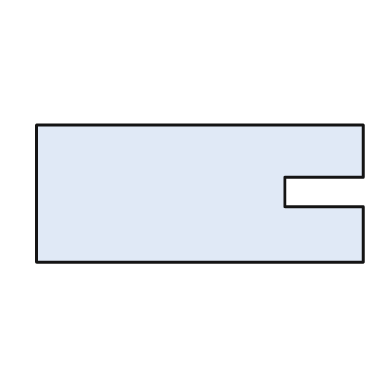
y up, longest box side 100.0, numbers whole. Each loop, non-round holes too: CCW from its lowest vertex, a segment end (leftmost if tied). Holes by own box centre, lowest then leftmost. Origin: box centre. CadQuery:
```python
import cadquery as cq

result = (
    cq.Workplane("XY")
    .moveTo(-50.0, -21.0)
    .lineTo(50.0, -21.0)
    .lineTo(50.0, -4.0)
    .lineTo(26.0, -4.0)
    .lineTo(26.0, 5.0)
    .lineTo(50.0, 5.0)
    .lineTo(50.0, 21.0)
    .lineTo(-50.0, 21.0)
    .close()
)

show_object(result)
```